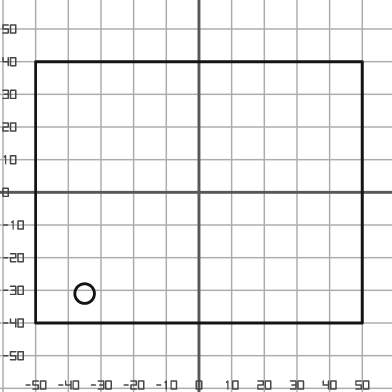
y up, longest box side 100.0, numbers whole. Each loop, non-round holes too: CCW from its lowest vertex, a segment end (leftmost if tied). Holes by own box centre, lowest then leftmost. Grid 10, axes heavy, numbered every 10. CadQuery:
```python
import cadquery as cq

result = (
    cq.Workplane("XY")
    .moveTo(-50.0, -40.0)
    .lineTo(50.0, -40.0)
    .lineTo(50.0, 40.0)
    .lineTo(-50.0, 40.0)
    .close()
    .moveTo(-35.0, -31.0)
    .circle(3.0)
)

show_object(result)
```